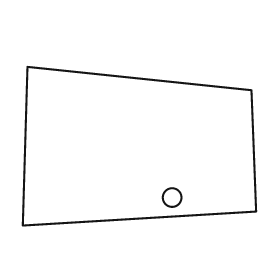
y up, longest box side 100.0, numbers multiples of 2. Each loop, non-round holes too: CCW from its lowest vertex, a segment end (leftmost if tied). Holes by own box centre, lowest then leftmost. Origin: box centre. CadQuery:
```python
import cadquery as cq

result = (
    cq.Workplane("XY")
    .moveTo(-50.0, -34.0)
    .lineTo(50.0, -28.0)
    .lineTo(48.0, 24.0)
    .lineTo(-48.0, 34.0)
    .close()
    .moveTo(14.0, -22.0)
    .circle(4.0)
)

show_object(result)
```